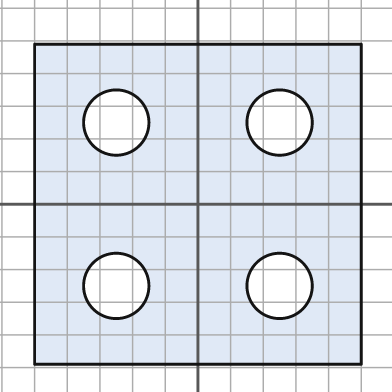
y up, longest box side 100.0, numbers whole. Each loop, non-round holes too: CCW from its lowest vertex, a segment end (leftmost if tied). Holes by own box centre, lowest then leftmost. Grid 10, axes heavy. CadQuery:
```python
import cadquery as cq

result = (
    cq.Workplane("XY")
    .moveTo(-50.0, -49.0)
    .lineTo(50.0, -49.0)
    .lineTo(50.0, 49.0)
    .lineTo(-50.0, 49.0)
    .close()
    .moveTo(-25.0, -25.0)
    .circle(10.0)
    .moveTo(25.0, -25.0)
    .circle(10.0)
    .moveTo(-25.0, 25.0)
    .circle(10.0)
    .moveTo(25.0, 25.0)
    .circle(10.0)
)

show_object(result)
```